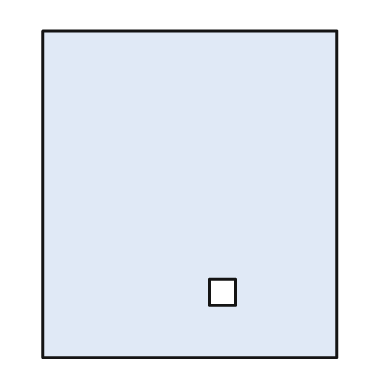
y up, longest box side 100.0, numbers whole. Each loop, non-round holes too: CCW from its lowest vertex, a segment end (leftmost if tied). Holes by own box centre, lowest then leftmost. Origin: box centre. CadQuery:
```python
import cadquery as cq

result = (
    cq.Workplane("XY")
    .moveTo(-45.0, -50.0)
    .lineTo(45.0, -50.0)
    .lineTo(45.0, 50.0)
    .lineTo(-45.0, 50.0)
    .close()
    .moveTo(6.0, -34.0)
    .lineTo(14.0, -34.0)
    .lineTo(14.0, -26.0)
    .lineTo(6.0, -26.0)
    .close()
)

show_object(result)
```